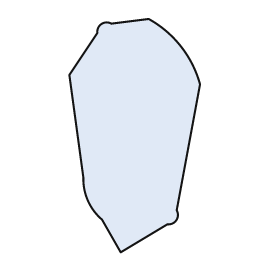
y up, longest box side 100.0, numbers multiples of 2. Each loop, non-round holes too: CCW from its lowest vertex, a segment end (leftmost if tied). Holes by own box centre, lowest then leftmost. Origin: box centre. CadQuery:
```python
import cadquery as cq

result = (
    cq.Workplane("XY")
    .moveTo(-6.0, -50.0)
    .lineTo(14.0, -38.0)
    .threePointArc((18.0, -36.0), (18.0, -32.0))
    .lineTo(28.0, 22.0)
    .threePointArc((20.0, 38.0), (6.0, 50.0))
    .lineTo(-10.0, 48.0)
    .threePointArc((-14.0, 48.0), (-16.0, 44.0))
    .lineTo(-28.0, 26.0)
    .lineTo(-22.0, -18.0)
    .threePointArc((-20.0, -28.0), (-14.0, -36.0))
    .close()
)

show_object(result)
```